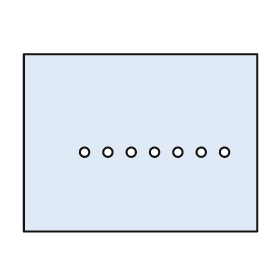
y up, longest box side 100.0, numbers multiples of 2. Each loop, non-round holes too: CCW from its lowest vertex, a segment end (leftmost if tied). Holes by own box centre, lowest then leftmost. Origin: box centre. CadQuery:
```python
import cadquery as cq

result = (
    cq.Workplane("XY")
    .moveTo(-50.0, -38.0)
    .lineTo(50.0, -38.0)
    .lineTo(50.0, 38.0)
    .lineTo(-50.0, 38.0)
    .close()
    .moveTo(-24.0, -4.0)
    .circle(2.0)
    .moveTo(-14.0, -4.0)
    .circle(2.0)
    .moveTo(-4.0, -4.0)
    .circle(2.0)
    .moveTo(6.0, -4.0)
    .circle(2.0)
    .moveTo(16.0, -4.0)
    .circle(2.0)
    .moveTo(26.0, -4.0)
    .circle(2.0)
    .moveTo(36.0, -4.0)
    .circle(2.0)
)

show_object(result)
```